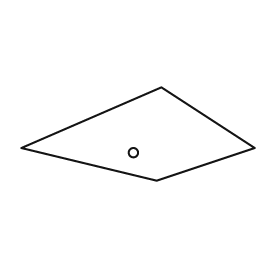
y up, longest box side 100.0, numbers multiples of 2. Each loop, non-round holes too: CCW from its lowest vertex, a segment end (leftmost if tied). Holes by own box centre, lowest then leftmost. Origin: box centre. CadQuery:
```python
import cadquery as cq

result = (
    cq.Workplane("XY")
    .moveTo(8.0, -20.0)
    .lineTo(50.0, -6.0)
    .lineTo(10.0, 20.0)
    .lineTo(-50.0, -6.0)
    .close()
    .moveTo(-2.0, -8.0)
    .circle(2.0)
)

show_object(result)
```